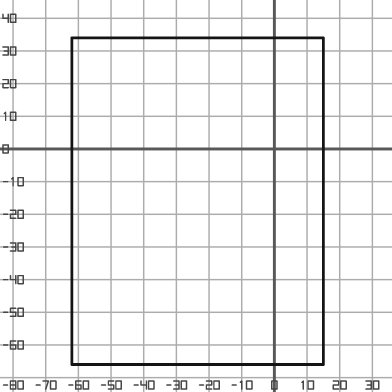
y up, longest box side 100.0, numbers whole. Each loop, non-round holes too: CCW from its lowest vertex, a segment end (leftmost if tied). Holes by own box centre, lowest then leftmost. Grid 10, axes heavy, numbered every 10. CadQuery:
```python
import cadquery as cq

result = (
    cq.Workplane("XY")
    .moveTo(-62.0, -66.0)
    .lineTo(15.0, -66.0)
    .lineTo(15.0, 34.0)
    .lineTo(-62.0, 34.0)
    .close()
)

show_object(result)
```